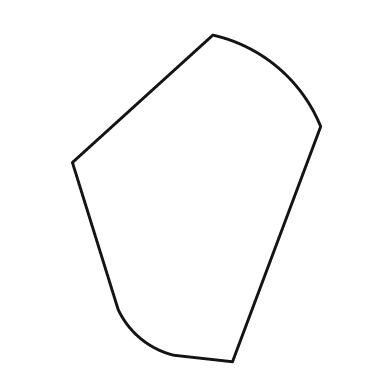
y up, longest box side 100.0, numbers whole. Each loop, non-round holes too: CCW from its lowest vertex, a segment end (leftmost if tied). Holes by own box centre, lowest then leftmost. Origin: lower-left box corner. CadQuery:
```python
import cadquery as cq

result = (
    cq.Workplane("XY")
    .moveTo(49.0, 0.0)
    .lineTo(76.0, 72.0)
    .threePointArc((63.0, 90.0), (43.0, 100.0))
    .lineTo(0.0, 61.0)
    .lineTo(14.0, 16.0)
    .threePointArc((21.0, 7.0), (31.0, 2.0))
    .close()
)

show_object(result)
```